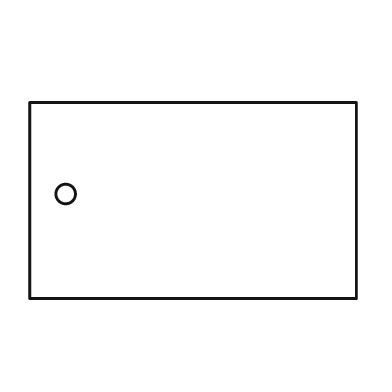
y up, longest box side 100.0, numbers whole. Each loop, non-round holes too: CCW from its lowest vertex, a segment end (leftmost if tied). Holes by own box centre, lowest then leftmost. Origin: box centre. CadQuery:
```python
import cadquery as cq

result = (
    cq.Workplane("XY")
    .moveTo(-50.0, -30.0)
    .lineTo(50.0, -30.0)
    .lineTo(50.0, 30.0)
    .lineTo(-50.0, 30.0)
    .close()
    .moveTo(-39.0, 2.0)
    .circle(3.0)
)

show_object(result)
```